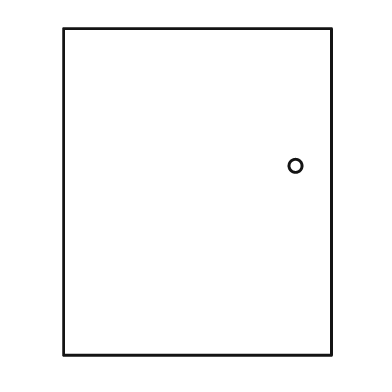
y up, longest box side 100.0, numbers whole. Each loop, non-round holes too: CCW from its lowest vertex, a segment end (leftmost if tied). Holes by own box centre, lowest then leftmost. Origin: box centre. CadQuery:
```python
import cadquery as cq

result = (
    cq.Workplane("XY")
    .moveTo(-41.0, -50.0)
    .lineTo(41.0, -50.0)
    .lineTo(41.0, 50.0)
    .lineTo(-41.0, 50.0)
    .close()
    .moveTo(30.0, 8.0)
    .circle(2.0)
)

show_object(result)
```